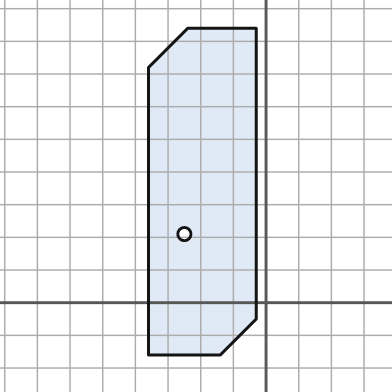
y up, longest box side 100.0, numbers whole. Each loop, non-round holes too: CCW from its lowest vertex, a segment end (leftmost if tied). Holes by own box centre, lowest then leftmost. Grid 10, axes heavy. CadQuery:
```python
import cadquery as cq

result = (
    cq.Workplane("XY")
    .moveTo(-36.0, -16.0)
    .lineTo(-14.0, -16.0)
    .lineTo(-3.0, -5.0)
    .lineTo(-3.0, 84.0)
    .lineTo(-24.0, 84.0)
    .lineTo(-36.0, 72.0)
    .close()
    .moveTo(-25.0, 21.0)
    .circle(2.0)
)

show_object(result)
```